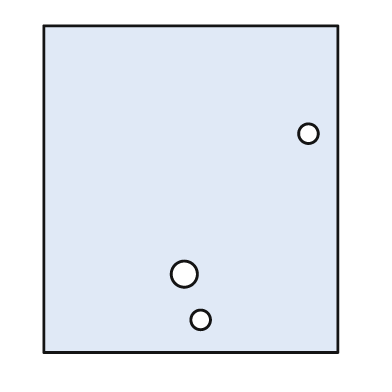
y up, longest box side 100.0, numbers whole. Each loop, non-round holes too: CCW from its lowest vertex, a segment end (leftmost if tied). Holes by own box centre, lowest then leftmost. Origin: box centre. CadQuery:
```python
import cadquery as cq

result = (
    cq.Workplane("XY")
    .moveTo(-45.0, -50.0)
    .lineTo(45.0, -50.0)
    .lineTo(45.0, 50.0)
    .lineTo(-45.0, 50.0)
    .close()
    .moveTo(3.0, -40.0)
    .circle(3.0)
    .moveTo(-2.0, -26.0)
    .circle(4.0)
    .moveTo(36.0, 17.0)
    .circle(3.0)
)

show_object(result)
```